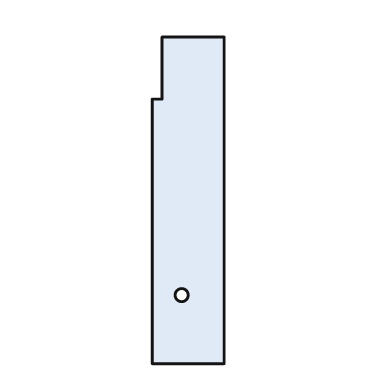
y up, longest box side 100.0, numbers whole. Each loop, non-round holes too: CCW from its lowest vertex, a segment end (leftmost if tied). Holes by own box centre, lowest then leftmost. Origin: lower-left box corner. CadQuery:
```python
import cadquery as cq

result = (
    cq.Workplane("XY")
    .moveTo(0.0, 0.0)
    .lineTo(22.0, 0.0)
    .lineTo(22.0, 100.0)
    .lineTo(3.0, 100.0)
    .lineTo(3.0, 81.0)
    .lineTo(0.0, 81.0)
    .close()
    .moveTo(9.0, 21.0)
    .circle(2.0)
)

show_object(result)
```